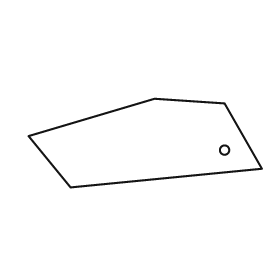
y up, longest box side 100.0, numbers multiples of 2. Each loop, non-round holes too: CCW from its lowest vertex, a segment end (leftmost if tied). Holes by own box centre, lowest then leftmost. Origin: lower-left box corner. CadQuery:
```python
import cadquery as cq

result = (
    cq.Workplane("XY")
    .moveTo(18.0, 0.0)
    .lineTo(100.0, 8.0)
    .lineTo(84.0, 36.0)
    .lineTo(54.0, 38.0)
    .lineTo(0.0, 22.0)
    .close()
    .moveTo(84.0, 16.0)
    .circle(2.0)
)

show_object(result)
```